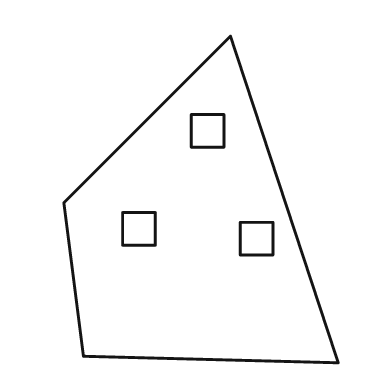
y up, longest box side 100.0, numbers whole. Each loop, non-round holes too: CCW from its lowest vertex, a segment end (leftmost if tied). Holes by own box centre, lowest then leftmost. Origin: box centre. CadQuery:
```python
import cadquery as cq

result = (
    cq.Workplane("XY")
    .moveTo(42.0, -50.0)
    .lineTo(9.0, 50.0)
    .lineTo(-42.0, -1.0)
    .lineTo(-36.0, -48.0)
    .close()
    .moveTo(12.0, -17.0)
    .lineTo(22.0, -17.0)
    .lineTo(22.0, -7.0)
    .lineTo(12.0, -7.0)
    .close()
    .moveTo(-24.0, -14.0)
    .lineTo(-14.0, -14.0)
    .lineTo(-14.0, -4.0)
    .lineTo(-24.0, -4.0)
    .close()
    .moveTo(-3.0, 16.0)
    .lineTo(7.0, 16.0)
    .lineTo(7.0, 26.0)
    .lineTo(-3.0, 26.0)
    .close()
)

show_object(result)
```